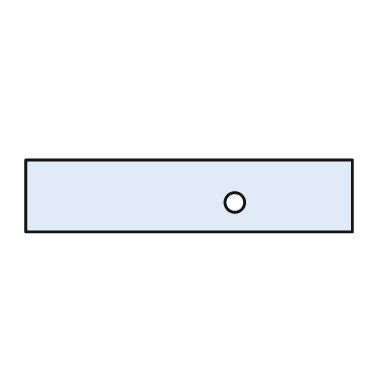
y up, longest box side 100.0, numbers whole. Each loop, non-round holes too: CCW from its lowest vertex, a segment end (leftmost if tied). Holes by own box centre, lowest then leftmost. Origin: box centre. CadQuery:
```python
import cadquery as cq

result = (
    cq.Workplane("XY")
    .moveTo(-50.0, -11.0)
    .lineTo(50.0, -11.0)
    .lineTo(50.0, 11.0)
    .lineTo(-50.0, 11.0)
    .close()
    .moveTo(14.0, -2.0)
    .circle(3.0)
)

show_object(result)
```